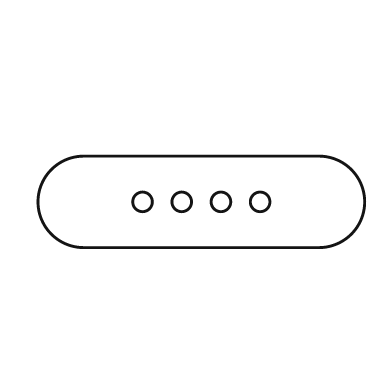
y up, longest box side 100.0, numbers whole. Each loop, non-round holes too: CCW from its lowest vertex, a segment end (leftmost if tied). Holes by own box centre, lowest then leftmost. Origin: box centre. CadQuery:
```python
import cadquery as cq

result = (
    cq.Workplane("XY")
    .moveTo(-36.0, -14.0)
    .lineTo(36.0, -14.0)
    .threePointArc((50.0, 0.0), (36.0, 14.0))
    .lineTo(-36.0, 14.0)
    .threePointArc((-50.0, 0.0), (-36.0, -14.0))
    .close()
    .moveTo(-18.0, 0.0)
    .circle(3.0)
    .moveTo(-6.0, 0.0)
    .circle(3.0)
    .moveTo(6.0, 0.0)
    .circle(3.0)
    .moveTo(18.0, 0.0)
    .circle(3.0)
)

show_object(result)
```